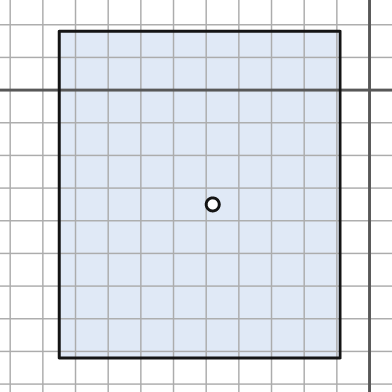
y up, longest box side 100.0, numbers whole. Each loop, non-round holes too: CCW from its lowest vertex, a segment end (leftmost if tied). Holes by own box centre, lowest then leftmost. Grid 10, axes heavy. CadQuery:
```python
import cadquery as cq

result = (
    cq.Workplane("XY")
    .moveTo(-95.0, -82.0)
    .lineTo(-9.0, -82.0)
    .lineTo(-9.0, 18.0)
    .lineTo(-95.0, 18.0)
    .close()
    .moveTo(-48.0, -35.0)
    .circle(2.0)
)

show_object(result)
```